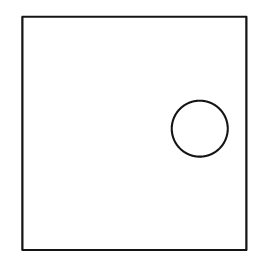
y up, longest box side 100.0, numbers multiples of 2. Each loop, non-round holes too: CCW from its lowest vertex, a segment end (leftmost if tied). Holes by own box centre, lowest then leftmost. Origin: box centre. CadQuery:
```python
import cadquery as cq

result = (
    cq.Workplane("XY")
    .moveTo(-48.0, -50.0)
    .lineTo(48.0, -50.0)
    .lineTo(48.0, 50.0)
    .lineTo(-48.0, 50.0)
    .close()
    .moveTo(28.0, 2.0)
    .circle(12.0)
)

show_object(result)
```